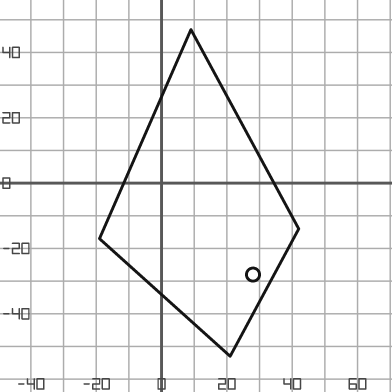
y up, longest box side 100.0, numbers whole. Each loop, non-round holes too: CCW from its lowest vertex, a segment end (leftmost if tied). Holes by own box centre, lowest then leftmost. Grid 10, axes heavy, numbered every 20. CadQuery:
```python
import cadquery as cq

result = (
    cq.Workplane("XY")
    .moveTo(21.0, -53.0)
    .lineTo(42.0, -14.0)
    .lineTo(9.0, 47.0)
    .lineTo(-19.0, -17.0)
    .close()
    .moveTo(28.0, -28.0)
    .circle(2.0)
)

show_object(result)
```